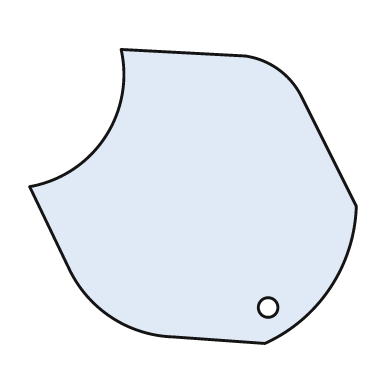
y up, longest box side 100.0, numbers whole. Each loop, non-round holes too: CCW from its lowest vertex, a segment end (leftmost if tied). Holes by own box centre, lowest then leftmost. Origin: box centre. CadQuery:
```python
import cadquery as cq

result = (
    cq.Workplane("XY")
    .moveTo(22.0, -45.0)
    .threePointArc((42.0, -28.0), (50.0, -3.0))
    .lineTo(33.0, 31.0)
    .threePointArc((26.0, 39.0), (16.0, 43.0))
    .lineTo(-22.0, 45.0)
    .threePointArc((-27.0, 18.0), (-50.0, 3.0))
    .lineTo(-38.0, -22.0)
    .threePointArc((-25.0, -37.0), (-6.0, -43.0))
    .close()
    .moveTo(23.0, -34.0)
    .circle(3.0)
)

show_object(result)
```